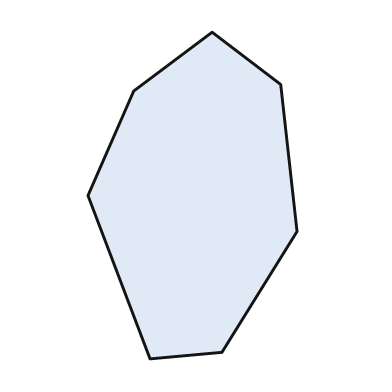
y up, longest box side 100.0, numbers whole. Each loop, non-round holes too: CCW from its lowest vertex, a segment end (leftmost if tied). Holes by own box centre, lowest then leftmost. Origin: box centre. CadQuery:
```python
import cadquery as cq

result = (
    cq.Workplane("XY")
    .moveTo(-13.0, -50.0)
    .lineTo(9.0, -48.0)
    .lineTo(32.0, -11.0)
    .lineTo(27.0, 34.0)
    .lineTo(6.0, 50.0)
    .lineTo(-18.0, 32.0)
    .lineTo(-32.0, 0.0)
    .close()
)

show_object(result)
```